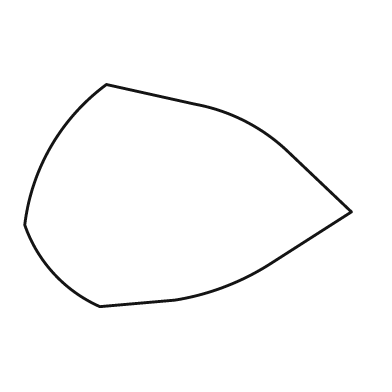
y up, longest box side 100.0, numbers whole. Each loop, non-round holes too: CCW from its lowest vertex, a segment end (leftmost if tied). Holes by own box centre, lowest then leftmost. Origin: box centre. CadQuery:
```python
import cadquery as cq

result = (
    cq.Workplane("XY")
    .moveTo(-27.0, -34.0)
    .lineTo(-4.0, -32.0)
    .threePointArc((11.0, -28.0), (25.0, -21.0))
    .lineTo(50.0, -5.0)
    .lineTo(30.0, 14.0)
    .threePointArc((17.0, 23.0), (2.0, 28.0))
    .lineTo(-25.0, 34.0)
    .threePointArc((-42.0, 15.0), (-50.0, -9.0))
    .threePointArc((-41.0, -24.0), (-27.0, -34.0))
    .close()
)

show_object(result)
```